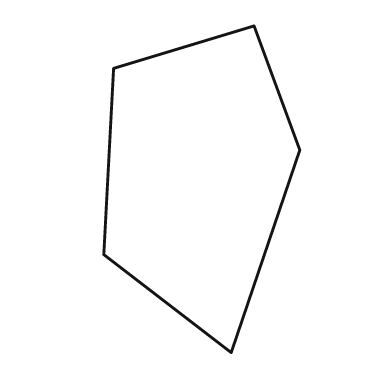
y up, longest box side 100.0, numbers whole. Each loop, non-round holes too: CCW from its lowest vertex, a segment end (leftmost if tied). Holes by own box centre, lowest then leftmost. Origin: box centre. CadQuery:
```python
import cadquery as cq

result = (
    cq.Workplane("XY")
    .moveTo(9.0, -50.0)
    .lineTo(30.0, 12.0)
    .lineTo(16.0, 50.0)
    .lineTo(-27.0, 37.0)
    .lineTo(-30.0, -20.0)
    .close()
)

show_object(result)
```